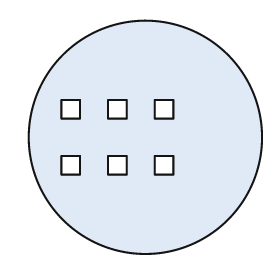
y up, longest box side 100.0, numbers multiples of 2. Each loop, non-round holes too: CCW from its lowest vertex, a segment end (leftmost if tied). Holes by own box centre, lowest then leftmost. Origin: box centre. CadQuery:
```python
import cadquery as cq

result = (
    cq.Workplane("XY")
    .moveTo(0.0, 0.0)
    .circle(50.0)
    .moveTo(-36.0, -16.0)
    .lineTo(-28.0, -16.0)
    .lineTo(-28.0, -8.0)
    .lineTo(-36.0, -8.0)
    .close()
    .moveTo(-16.0, -16.0)
    .lineTo(-8.0, -16.0)
    .lineTo(-8.0, -8.0)
    .lineTo(-16.0, -8.0)
    .close()
    .moveTo(4.0, -16.0)
    .lineTo(12.0, -16.0)
    .lineTo(12.0, -8.0)
    .lineTo(4.0, -8.0)
    .close()
    .moveTo(-36.0, 8.0)
    .lineTo(-28.0, 8.0)
    .lineTo(-28.0, 16.0)
    .lineTo(-36.0, 16.0)
    .close()
    .moveTo(-16.0, 8.0)
    .lineTo(-8.0, 8.0)
    .lineTo(-8.0, 16.0)
    .lineTo(-16.0, 16.0)
    .close()
    .moveTo(4.0, 8.0)
    .lineTo(12.0, 8.0)
    .lineTo(12.0, 16.0)
    .lineTo(4.0, 16.0)
    .close()
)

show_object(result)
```